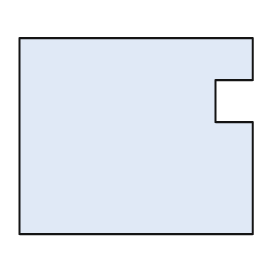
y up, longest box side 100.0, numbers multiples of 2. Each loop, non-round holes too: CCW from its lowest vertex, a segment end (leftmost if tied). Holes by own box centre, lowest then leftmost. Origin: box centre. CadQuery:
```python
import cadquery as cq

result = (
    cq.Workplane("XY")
    .moveTo(-50.0, -42.0)
    .lineTo(50.0, -42.0)
    .lineTo(50.0, 6.0)
    .lineTo(34.0, 6.0)
    .lineTo(34.0, 24.0)
    .lineTo(50.0, 24.0)
    .lineTo(50.0, 42.0)
    .lineTo(-50.0, 42.0)
    .close()
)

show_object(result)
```